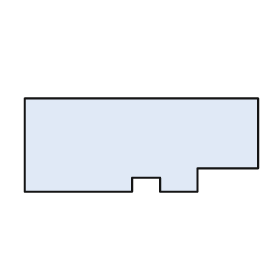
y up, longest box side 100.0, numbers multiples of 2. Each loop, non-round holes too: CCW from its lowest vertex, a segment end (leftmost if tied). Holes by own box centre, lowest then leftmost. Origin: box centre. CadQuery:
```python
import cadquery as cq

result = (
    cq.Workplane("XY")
    .moveTo(-50.0, -20.0)
    .lineTo(-4.0, -20.0)
    .lineTo(-4.0, -14.0)
    .lineTo(8.0, -14.0)
    .lineTo(8.0, -20.0)
    .lineTo(24.0, -20.0)
    .lineTo(24.0, -10.0)
    .lineTo(50.0, -10.0)
    .lineTo(50.0, 20.0)
    .lineTo(-50.0, 20.0)
    .close()
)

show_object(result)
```